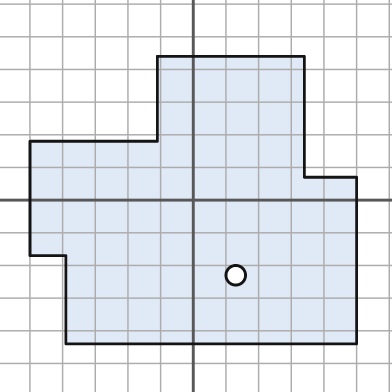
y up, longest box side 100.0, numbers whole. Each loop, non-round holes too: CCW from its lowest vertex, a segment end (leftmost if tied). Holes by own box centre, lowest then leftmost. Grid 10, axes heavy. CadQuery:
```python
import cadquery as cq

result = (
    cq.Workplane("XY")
    .moveTo(-39.0, -44.0)
    .lineTo(50.0, -44.0)
    .lineTo(50.0, 7.0)
    .lineTo(34.0, 7.0)
    .lineTo(34.0, 44.0)
    .lineTo(-11.0, 44.0)
    .lineTo(-11.0, 18.0)
    .lineTo(-50.0, 18.0)
    .lineTo(-50.0, -17.0)
    .lineTo(-39.0, -17.0)
    .close()
    .moveTo(13.0, -23.0)
    .circle(3.0)
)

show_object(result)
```